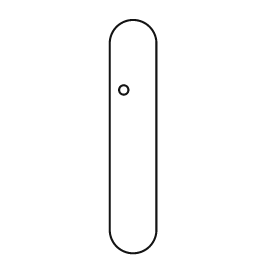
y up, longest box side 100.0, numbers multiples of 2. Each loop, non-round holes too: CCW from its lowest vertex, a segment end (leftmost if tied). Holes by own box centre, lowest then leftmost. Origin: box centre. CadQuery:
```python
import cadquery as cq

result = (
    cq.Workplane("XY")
    .moveTo(-10.0, -40.0)
    .threePointArc((0.0, -50.0), (10.0, -40.0))
    .lineTo(10.0, 40.0)
    .threePointArc((0.0, 50.0), (-10.0, 40.0))
    .close()
    .moveTo(-4.0, 20.0)
    .circle(2.0)
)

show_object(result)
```